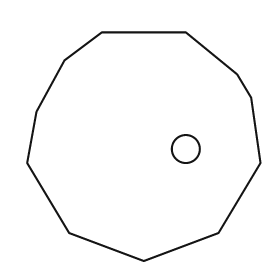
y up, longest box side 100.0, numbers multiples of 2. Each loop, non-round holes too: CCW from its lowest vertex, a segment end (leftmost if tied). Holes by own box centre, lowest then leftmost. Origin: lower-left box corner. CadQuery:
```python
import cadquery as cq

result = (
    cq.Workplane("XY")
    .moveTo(50.0, 0.0)
    .lineTo(82.0, 12.0)
    .lineTo(100.0, 42.0)
    .lineTo(96.0, 70.0)
    .lineTo(90.0, 80.0)
    .lineTo(68.0, 98.0)
    .lineTo(32.0, 98.0)
    .lineTo(16.0, 86.0)
    .lineTo(4.0, 64.0)
    .lineTo(0.0, 42.0)
    .lineTo(18.0, 12.0)
    .close()
    .moveTo(68.0, 48.0)
    .circle(6.0)
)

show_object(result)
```